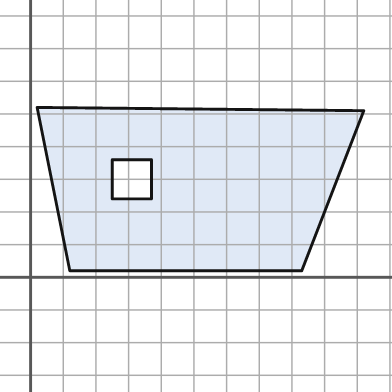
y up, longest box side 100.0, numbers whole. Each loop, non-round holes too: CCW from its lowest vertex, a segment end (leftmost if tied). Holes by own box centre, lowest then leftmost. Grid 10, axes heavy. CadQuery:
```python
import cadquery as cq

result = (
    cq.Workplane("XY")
    .moveTo(12.0, 2.0)
    .lineTo(83.0, 2.0)
    .lineTo(102.0, 51.0)
    .lineTo(2.0, 52.0)
    .close()
    .moveTo(25.0, 24.0)
    .lineTo(37.0, 24.0)
    .lineTo(37.0, 36.0)
    .lineTo(25.0, 36.0)
    .close()
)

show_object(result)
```